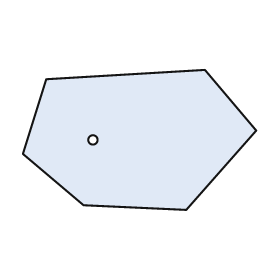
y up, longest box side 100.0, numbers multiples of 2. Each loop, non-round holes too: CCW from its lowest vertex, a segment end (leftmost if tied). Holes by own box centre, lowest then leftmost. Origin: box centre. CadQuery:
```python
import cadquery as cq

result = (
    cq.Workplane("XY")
    .moveTo(20.0, -30.0)
    .lineTo(50.0, 4.0)
    .lineTo(28.0, 30.0)
    .lineTo(-40.0, 26.0)
    .lineTo(-50.0, -6.0)
    .lineTo(-24.0, -28.0)
    .close()
    .moveTo(-20.0, 0.0)
    .circle(2.0)
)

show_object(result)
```